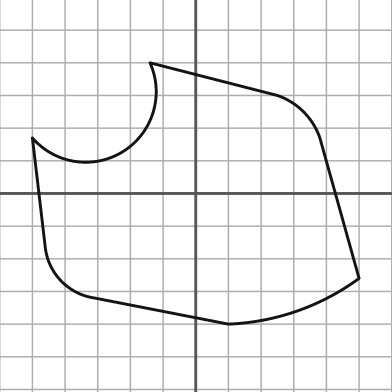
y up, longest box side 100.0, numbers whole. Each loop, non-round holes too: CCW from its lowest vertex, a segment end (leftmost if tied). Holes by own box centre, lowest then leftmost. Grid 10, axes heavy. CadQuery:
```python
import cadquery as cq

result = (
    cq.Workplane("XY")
    .moveTo(10.0, -40.0)
    .threePointArc((31.0, -36.0), (50.0, -26.0))
    .lineTo(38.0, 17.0)
    .threePointArc((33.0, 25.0), (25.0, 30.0))
    .lineTo(-14.0, 40.0)
    .threePointArc((-22.0, 13.0), (-50.0, 17.0))
    .lineTo(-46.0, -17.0)
    .threePointArc((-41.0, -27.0), (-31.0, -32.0))
    .close()
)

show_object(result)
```